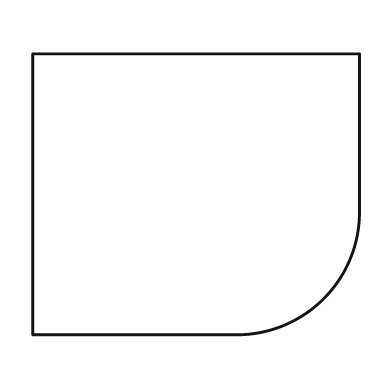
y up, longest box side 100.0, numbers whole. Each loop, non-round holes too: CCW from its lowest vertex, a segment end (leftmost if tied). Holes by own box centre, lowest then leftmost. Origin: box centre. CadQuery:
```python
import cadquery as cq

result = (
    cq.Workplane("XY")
    .moveTo(-50.0, -43.0)
    .lineTo(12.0, -43.0)
    .threePointArc((39.0, -32.0), (50.0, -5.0))
    .lineTo(50.0, 43.0)
    .lineTo(-50.0, 43.0)
    .close()
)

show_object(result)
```